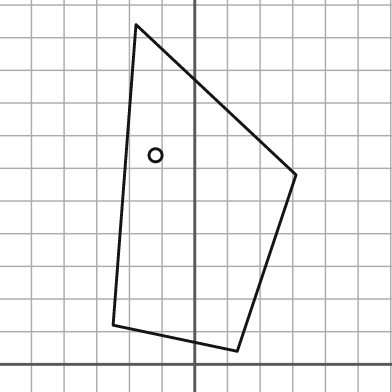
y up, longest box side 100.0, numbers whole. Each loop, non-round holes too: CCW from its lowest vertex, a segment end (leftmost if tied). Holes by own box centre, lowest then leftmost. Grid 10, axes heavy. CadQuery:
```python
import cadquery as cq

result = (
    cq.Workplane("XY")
    .moveTo(13.0, 4.0)
    .lineTo(31.0, 58.0)
    .lineTo(-18.0, 104.0)
    .lineTo(-25.0, 12.0)
    .close()
    .moveTo(-12.0, 64.0)
    .circle(2.0)
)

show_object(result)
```